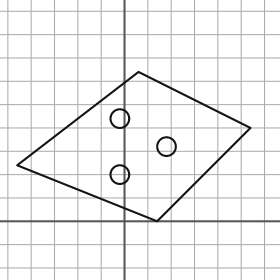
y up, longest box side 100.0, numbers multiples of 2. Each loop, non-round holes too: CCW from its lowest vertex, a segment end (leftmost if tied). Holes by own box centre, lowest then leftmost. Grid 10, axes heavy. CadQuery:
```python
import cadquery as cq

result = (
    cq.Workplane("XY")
    .moveTo(14.0, 0.0)
    .lineTo(54.0, 40.0)
    .lineTo(6.0, 64.0)
    .lineTo(-46.0, 24.0)
    .close()
    .moveTo(-2.0, 20.0)
    .circle(4.0)
    .moveTo(18.0, 32.0)
    .circle(4.0)
    .moveTo(-2.0, 44.0)
    .circle(4.0)
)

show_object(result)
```